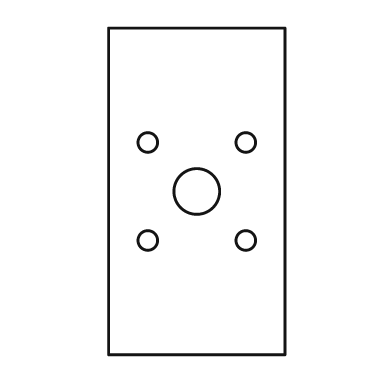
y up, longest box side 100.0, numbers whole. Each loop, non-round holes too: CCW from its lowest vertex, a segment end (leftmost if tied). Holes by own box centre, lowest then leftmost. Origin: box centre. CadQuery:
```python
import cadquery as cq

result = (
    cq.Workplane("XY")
    .moveTo(-27.0, -50.0)
    .lineTo(27.0, -50.0)
    .lineTo(27.0, 50.0)
    .lineTo(-27.0, 50.0)
    .close()
    .moveTo(-15.0, -15.0)
    .circle(3.0)
    .moveTo(15.0, -15.0)
    .circle(3.0)
    .moveTo(0.0, 0.0)
    .circle(7.0)
    .moveTo(-15.0, 15.0)
    .circle(3.0)
    .moveTo(15.0, 15.0)
    .circle(3.0)
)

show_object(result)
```